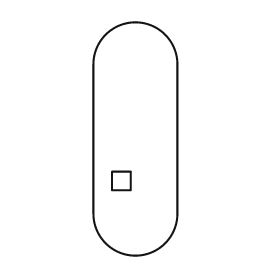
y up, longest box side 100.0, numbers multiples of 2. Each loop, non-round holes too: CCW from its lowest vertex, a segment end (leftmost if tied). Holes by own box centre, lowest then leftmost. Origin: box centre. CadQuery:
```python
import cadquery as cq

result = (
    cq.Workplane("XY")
    .moveTo(-18.0, -32.0)
    .threePointArc((0.0, -50.0), (18.0, -32.0))
    .lineTo(18.0, 32.0)
    .threePointArc((0.0, 50.0), (-18.0, 32.0))
    .close()
    .moveTo(-10.0, -22.0)
    .lineTo(-2.0, -22.0)
    .lineTo(-2.0, -14.0)
    .lineTo(-10.0, -14.0)
    .close()
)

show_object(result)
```